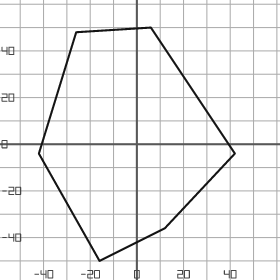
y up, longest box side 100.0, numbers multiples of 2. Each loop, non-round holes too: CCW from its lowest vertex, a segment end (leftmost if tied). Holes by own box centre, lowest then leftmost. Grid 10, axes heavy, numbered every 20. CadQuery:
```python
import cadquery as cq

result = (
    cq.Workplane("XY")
    .moveTo(-16.0, -50.0)
    .lineTo(12.0, -36.0)
    .lineTo(42.0, -4.0)
    .lineTo(6.0, 50.0)
    .lineTo(-26.0, 48.0)
    .lineTo(-42.0, -4.0)
    .close()
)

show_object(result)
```